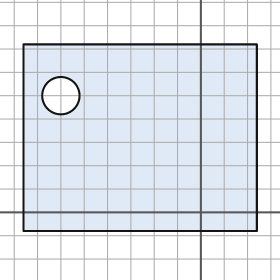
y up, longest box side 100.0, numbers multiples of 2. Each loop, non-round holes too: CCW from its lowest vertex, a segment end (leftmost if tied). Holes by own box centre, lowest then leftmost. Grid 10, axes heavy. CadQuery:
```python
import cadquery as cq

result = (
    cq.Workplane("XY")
    .moveTo(-76.0, -8.0)
    .lineTo(24.0, -8.0)
    .lineTo(24.0, 72.0)
    .lineTo(-76.0, 72.0)
    .close()
    .moveTo(-60.0, 50.0)
    .circle(8.0)
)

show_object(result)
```